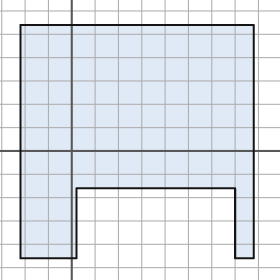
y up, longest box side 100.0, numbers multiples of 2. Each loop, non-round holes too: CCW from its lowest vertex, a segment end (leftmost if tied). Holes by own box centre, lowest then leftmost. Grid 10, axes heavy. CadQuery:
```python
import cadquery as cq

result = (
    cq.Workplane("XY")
    .moveTo(-22.0, -46.0)
    .lineTo(2.0, -46.0)
    .lineTo(2.0, -16.0)
    .lineTo(70.0, -16.0)
    .lineTo(70.0, -46.0)
    .lineTo(78.0, -46.0)
    .lineTo(78.0, 54.0)
    .lineTo(-22.0, 54.0)
    .close()
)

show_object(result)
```